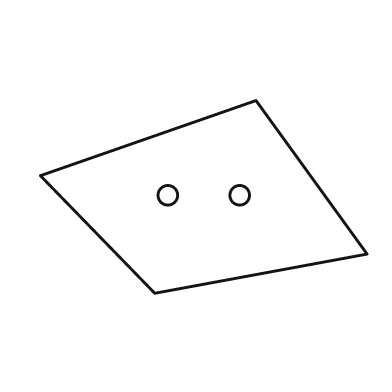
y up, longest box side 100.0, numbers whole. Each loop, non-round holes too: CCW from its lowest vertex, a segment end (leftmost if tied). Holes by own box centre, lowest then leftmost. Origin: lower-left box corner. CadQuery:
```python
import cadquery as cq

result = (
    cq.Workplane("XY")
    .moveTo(35.0, 0.0)
    .lineTo(100.0, 12.0)
    .lineTo(66.0, 59.0)
    .lineTo(0.0, 36.0)
    .close()
    .moveTo(39.0, 30.0)
    .circle(3.0)
    .moveTo(61.0, 30.0)
    .circle(3.0)
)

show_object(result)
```